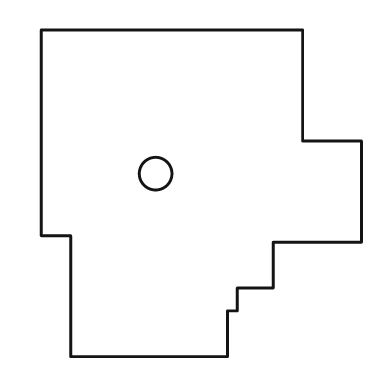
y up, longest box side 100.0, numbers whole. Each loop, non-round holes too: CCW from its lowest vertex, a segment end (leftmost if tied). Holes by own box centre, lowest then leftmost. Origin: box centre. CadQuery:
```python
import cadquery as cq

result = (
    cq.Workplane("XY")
    .moveTo(-40.0, -50.0)
    .lineTo(8.0, -50.0)
    .lineTo(8.0, -36.0)
    .lineTo(11.0, -36.0)
    .lineTo(11.0, -29.0)
    .lineTo(22.0, -29.0)
    .lineTo(22.0, -15.0)
    .lineTo(49.0, -15.0)
    .lineTo(49.0, 16.0)
    .lineTo(31.0, 16.0)
    .lineTo(31.0, 50.0)
    .lineTo(-49.0, 50.0)
    .lineTo(-49.0, -13.0)
    .lineTo(-40.0, -13.0)
    .close()
    .moveTo(-14.0, 6.0)
    .circle(5.0)
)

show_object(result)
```